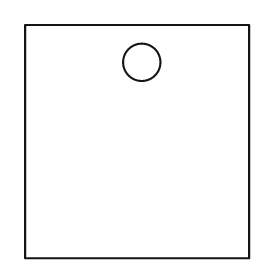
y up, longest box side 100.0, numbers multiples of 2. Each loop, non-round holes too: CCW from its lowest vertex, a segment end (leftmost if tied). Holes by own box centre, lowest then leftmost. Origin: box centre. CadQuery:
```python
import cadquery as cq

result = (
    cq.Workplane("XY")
    .moveTo(-48.0, -50.0)
    .lineTo(48.0, -50.0)
    .lineTo(48.0, 50.0)
    .lineTo(-48.0, 50.0)
    .close()
    .moveTo(2.0, 34.0)
    .circle(8.0)
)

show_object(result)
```